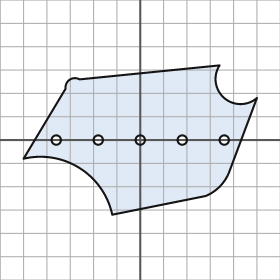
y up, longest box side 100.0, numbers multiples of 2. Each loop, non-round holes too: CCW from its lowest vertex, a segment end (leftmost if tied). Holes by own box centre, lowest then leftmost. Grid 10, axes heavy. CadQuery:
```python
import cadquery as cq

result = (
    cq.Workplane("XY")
    .moveTo(-12.0, -32.0)
    .lineTo(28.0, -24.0)
    .threePointArc((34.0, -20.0), (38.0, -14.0))
    .lineTo(50.0, 18.0)
    .threePointArc((36.0, 18.0), (34.0, 32.0))
    .lineTo(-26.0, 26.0)
    .threePointArc((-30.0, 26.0), (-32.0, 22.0))
    .lineTo(-50.0, -8.0)
    .threePointArc((-26.0, -12.0), (-12.0, -32.0))
    .close()
    .moveTo(-36.0, 0.0)
    .circle(2.0)
    .moveTo(-18.0, 0.0)
    .circle(2.0)
    .moveTo(0.0, 0.0)
    .circle(2.0)
    .moveTo(18.0, 0.0)
    .circle(2.0)
    .moveTo(36.0, 0.0)
    .circle(2.0)
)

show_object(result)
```